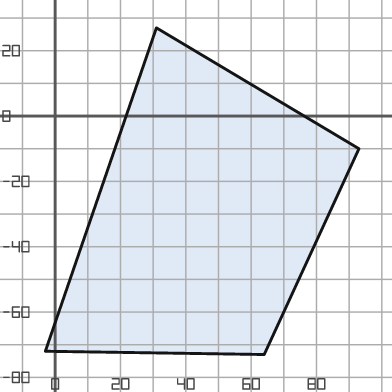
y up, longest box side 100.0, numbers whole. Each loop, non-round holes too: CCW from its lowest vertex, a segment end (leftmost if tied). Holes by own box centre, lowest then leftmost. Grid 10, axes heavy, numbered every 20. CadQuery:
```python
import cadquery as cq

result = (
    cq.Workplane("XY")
    .moveTo(64.0, -73.0)
    .lineTo(93.0, -10.0)
    .lineTo(31.0, 27.0)
    .lineTo(-3.0, -72.0)
    .close()
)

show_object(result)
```